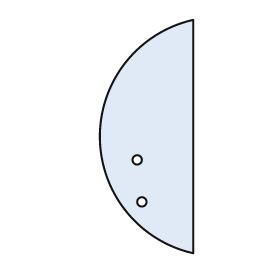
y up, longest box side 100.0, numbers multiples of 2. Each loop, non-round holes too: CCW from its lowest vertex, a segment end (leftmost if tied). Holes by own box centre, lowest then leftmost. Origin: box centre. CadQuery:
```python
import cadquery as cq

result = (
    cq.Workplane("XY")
    .moveTo(20.0, -50.0)
    .lineTo(20.0, 50.0)
    .threePointArc((-20.0, 0.0), (20.0, -50.0))
    .close()
    .moveTo(-2.0, -28.0)
    .circle(2.0)
    .moveTo(-4.0, -10.0)
    .circle(2.0)
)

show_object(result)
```